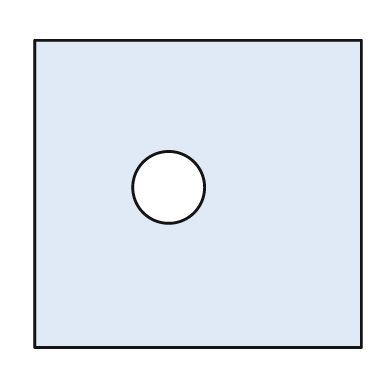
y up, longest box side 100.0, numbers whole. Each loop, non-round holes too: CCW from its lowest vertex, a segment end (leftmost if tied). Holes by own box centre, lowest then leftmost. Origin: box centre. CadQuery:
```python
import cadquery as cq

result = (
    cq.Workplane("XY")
    .moveTo(-50.0, -47.0)
    .lineTo(50.0, -47.0)
    .lineTo(50.0, 47.0)
    .lineTo(-50.0, 47.0)
    .close()
    .moveTo(-9.0, 2.0)
    .circle(11.0)
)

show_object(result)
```